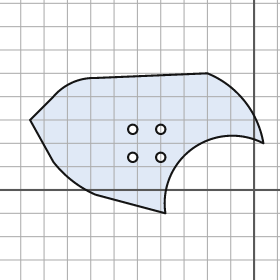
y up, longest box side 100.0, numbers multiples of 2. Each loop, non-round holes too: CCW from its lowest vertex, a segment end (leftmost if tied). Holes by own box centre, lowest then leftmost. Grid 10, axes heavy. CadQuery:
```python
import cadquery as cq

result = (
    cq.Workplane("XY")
    .moveTo(-38.0, -10.0)
    .threePointArc((-26.0, 18.0), (4.0, 20.0))
    .threePointArc((-4.0, 38.0), (-20.0, 50.0))
    .lineTo(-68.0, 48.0)
    .threePointArc((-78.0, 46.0), (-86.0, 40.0))
    .lineTo(-96.0, 30.0)
    .lineTo(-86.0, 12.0)
    .threePointArc((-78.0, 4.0), (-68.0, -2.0))
    .close()
    .moveTo(-52.0, 14.0)
    .circle(2.0)
    .moveTo(-40.0, 14.0)
    .circle(2.0)
    .moveTo(-52.0, 26.0)
    .circle(2.0)
    .moveTo(-40.0, 26.0)
    .circle(2.0)
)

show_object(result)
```